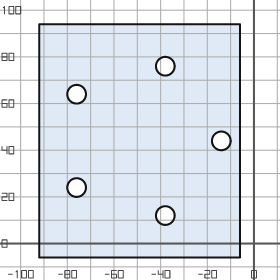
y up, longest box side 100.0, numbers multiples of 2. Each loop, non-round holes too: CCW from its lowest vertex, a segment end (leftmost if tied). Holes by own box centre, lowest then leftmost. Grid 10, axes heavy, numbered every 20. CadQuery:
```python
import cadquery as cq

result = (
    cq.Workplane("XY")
    .moveTo(-92.0, -6.0)
    .lineTo(-6.0, -6.0)
    .lineTo(-6.0, 94.0)
    .lineTo(-92.0, 94.0)
    .close()
    .moveTo(-38.0, 12.0)
    .circle(4.0)
    .moveTo(-76.0, 24.0)
    .circle(4.0)
    .moveTo(-14.0, 44.0)
    .circle(4.0)
    .moveTo(-76.0, 64.0)
    .circle(4.0)
    .moveTo(-38.0, 76.0)
    .circle(4.0)
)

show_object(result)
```